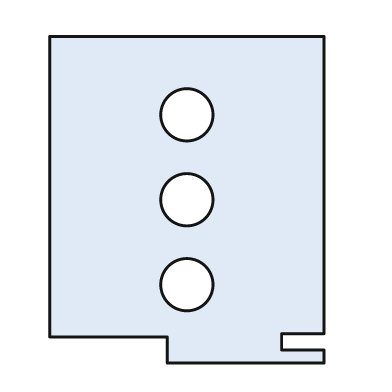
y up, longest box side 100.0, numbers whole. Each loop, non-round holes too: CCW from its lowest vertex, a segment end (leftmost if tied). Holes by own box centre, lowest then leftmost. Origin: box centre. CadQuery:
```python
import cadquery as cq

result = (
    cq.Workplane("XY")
    .moveTo(-6.0, -50.0)
    .lineTo(42.0, -50.0)
    .lineTo(42.0, -46.0)
    .lineTo(29.0, -46.0)
    .lineTo(29.0, -41.0)
    .lineTo(42.0, -41.0)
    .lineTo(42.0, 50.0)
    .lineTo(-42.0, 50.0)
    .lineTo(-42.0, -42.0)
    .lineTo(-6.0, -42.0)
    .close()
    .moveTo(0.0, -26.0)
    .circle(8.0)
    .moveTo(0.0, 0.0)
    .circle(8.0)
    .moveTo(0.0, 26.0)
    .circle(8.0)
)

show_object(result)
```